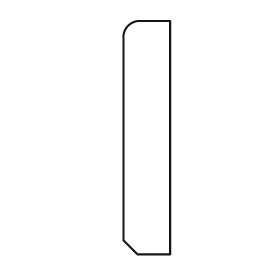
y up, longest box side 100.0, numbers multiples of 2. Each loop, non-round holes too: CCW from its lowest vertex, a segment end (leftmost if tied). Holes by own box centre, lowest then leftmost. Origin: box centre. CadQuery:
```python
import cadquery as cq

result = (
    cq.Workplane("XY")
    .moveTo(-4.0, -50.0)
    .lineTo(10.0, -50.0)
    .lineTo(10.0, 50.0)
    .lineTo(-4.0, 50.0)
    .threePointArc((-8.0, 48.0), (-10.0, 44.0))
    .lineTo(-10.0, -44.0)
    .close()
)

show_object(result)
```